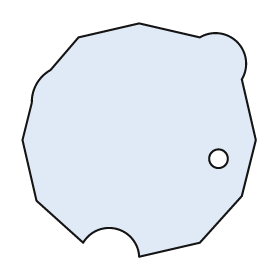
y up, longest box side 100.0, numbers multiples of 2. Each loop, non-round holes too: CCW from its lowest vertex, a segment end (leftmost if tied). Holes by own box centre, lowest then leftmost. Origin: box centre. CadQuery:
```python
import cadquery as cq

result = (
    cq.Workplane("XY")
    .moveTo(0.0, -50.0)
    .lineTo(26.0, -44.0)
    .lineTo(44.0, -24.0)
    .lineTo(50.0, 0.0)
    .lineTo(44.0, 26.0)
    .threePointArc((42.0, 42.0), (26.0, 44.0))
    .lineTo(0.0, 50.0)
    .lineTo(-26.0, 44.0)
    .lineTo(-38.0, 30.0)
    .threePointArc((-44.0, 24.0), (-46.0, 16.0))
    .lineTo(-50.0, 0.0)
    .lineTo(-44.0, -26.0)
    .lineTo(-24.0, -44.0)
    .threePointArc((-10.0, -38.0), (0.0, -50.0))
    .close()
    .moveTo(34.0, -8.0)
    .circle(4.0)
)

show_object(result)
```